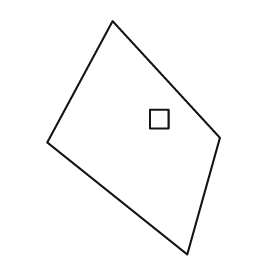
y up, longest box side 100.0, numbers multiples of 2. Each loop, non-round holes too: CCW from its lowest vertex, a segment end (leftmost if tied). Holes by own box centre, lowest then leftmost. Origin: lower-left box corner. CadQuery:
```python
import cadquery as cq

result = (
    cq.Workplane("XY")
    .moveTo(60.0, 0.0)
    .lineTo(74.0, 50.0)
    .lineTo(28.0, 100.0)
    .lineTo(0.0, 48.0)
    .close()
    .moveTo(44.0, 54.0)
    .lineTo(52.0, 54.0)
    .lineTo(52.0, 62.0)
    .lineTo(44.0, 62.0)
    .close()
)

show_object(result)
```